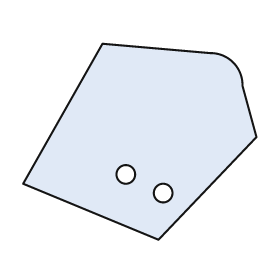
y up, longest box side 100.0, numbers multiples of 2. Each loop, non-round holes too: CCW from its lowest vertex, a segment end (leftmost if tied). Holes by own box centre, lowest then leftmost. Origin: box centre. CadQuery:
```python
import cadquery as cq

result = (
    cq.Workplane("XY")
    .moveTo(8.0, -42.0)
    .lineTo(50.0, 2.0)
    .lineTo(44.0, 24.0)
    .threePointArc((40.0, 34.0), (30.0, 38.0))
    .lineTo(-16.0, 42.0)
    .lineTo(-50.0, -18.0)
    .close()
    .moveTo(10.0, -22.0)
    .circle(4.0)
    .moveTo(-6.0, -14.0)
    .circle(4.0)
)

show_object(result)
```